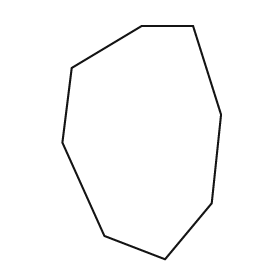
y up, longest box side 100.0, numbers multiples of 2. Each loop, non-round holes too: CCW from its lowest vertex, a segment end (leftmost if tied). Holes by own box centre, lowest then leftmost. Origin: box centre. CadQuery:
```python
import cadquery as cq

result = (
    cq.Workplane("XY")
    .moveTo(10.0, -50.0)
    .lineTo(30.0, -26.0)
    .lineTo(34.0, 12.0)
    .lineTo(22.0, 50.0)
    .lineTo(0.0, 50.0)
    .lineTo(-30.0, 32.0)
    .lineTo(-34.0, 0.0)
    .lineTo(-16.0, -40.0)
    .close()
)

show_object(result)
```